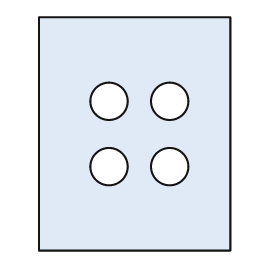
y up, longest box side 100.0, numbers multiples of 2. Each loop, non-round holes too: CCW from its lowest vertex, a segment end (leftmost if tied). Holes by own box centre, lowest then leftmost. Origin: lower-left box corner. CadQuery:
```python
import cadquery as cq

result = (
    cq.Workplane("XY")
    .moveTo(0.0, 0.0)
    .lineTo(82.0, 0.0)
    .lineTo(82.0, 100.0)
    .lineTo(0.0, 100.0)
    .close()
    .moveTo(30.0, 36.0)
    .circle(8.0)
    .moveTo(56.0, 36.0)
    .circle(8.0)
    .moveTo(30.0, 64.0)
    .circle(8.0)
    .moveTo(56.0, 64.0)
    .circle(8.0)
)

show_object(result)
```